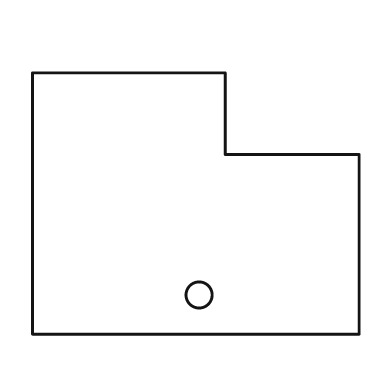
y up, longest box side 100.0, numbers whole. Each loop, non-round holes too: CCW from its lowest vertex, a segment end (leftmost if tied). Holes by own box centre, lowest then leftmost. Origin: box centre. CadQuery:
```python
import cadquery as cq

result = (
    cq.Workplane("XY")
    .moveTo(-50.0, -40.0)
    .lineTo(50.0, -40.0)
    .lineTo(50.0, 15.0)
    .lineTo(9.0, 15.0)
    .lineTo(9.0, 40.0)
    .lineTo(-50.0, 40.0)
    .close()
    .moveTo(1.0, -28.0)
    .circle(4.0)
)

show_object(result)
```